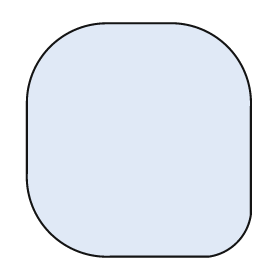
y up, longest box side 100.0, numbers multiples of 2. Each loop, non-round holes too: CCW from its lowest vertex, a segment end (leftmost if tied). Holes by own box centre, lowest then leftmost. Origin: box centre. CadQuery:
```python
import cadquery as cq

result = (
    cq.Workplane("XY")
    .moveTo(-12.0, -50.0)
    .lineTo(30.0, -50.0)
    .threePointArc((42.0, -44.0), (48.0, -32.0))
    .lineTo(48.0, 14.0)
    .threePointArc((38.0, 40.0), (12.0, 50.0))
    .lineTo(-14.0, 50.0)
    .threePointArc((-38.0, 40.0), (-48.0, 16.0))
    .lineTo(-48.0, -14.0)
    .threePointArc((-38.0, -40.0), (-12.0, -50.0))
    .close()
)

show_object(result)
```